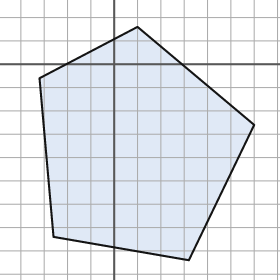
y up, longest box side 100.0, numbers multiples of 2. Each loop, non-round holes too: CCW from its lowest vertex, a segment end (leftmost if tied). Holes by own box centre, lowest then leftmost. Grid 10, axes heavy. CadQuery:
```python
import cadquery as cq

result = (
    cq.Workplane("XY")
    .moveTo(32.0, -84.0)
    .lineTo(60.0, -26.0)
    .lineTo(10.0, 16.0)
    .lineTo(-32.0, -6.0)
    .lineTo(-26.0, -74.0)
    .close()
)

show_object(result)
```